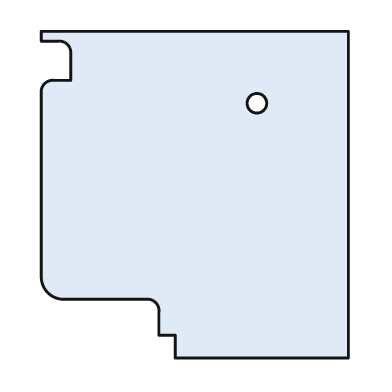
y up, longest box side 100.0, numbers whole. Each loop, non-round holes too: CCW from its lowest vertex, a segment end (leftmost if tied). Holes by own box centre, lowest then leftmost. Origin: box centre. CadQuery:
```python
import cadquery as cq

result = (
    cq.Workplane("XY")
    .moveTo(-6.0, -50.0)
    .lineTo(47.0, -50.0)
    .lineTo(47.0, 50.0)
    .lineTo(-47.0, 50.0)
    .lineTo(-47.0, 47.0)
    .lineTo(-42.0, 47.0)
    .threePointArc((-39.0, 46.0), (-38.0, 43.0))
    .lineTo(-38.0, 35.0)
    .lineTo(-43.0, 35.0)
    .threePointArc((-46.0, 34.0), (-47.0, 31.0))
    .lineTo(-47.0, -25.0)
    .threePointArc((-45.0, -30.0), (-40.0, -32.0))
    .lineTo(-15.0, -32.0)
    .threePointArc((-12.0, -33.0), (-11.0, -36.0))
    .lineTo(-11.0, -43.0)
    .lineTo(-6.0, -43.0)
    .close()
    .moveTo(19.0, 28.0)
    .circle(3.0)
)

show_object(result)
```